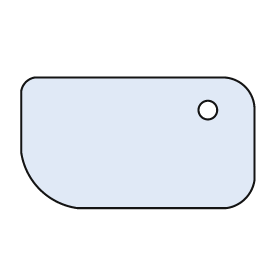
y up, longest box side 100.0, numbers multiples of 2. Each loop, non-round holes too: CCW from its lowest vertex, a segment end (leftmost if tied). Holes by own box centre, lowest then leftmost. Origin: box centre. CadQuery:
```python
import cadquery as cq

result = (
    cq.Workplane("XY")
    .moveTo(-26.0, -28.0)
    .lineTo(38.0, -28.0)
    .threePointArc((46.0, -24.0), (50.0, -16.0))
    .lineTo(50.0, 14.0)
    .threePointArc((46.0, 24.0), (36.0, 28.0))
    .lineTo(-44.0, 28.0)
    .threePointArc((-48.0, 26.0), (-50.0, 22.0))
    .lineTo(-50.0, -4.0)
    .threePointArc((-42.0, -20.0), (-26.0, -28.0))
    .close()
    .moveTo(30.0, 14.0)
    .circle(4.0)
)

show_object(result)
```